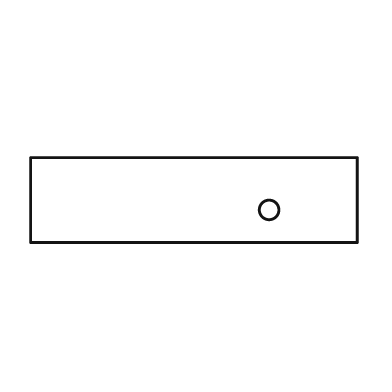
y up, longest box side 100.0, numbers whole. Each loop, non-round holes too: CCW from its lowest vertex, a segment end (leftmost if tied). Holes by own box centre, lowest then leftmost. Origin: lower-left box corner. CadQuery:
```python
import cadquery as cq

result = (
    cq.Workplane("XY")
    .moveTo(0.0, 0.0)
    .lineTo(100.0, 0.0)
    .lineTo(100.0, 26.0)
    .lineTo(0.0, 26.0)
    .close()
    .moveTo(73.0, 10.0)
    .circle(3.0)
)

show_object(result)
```